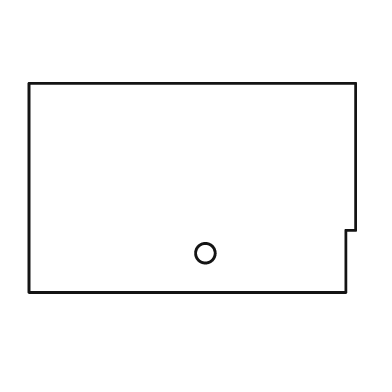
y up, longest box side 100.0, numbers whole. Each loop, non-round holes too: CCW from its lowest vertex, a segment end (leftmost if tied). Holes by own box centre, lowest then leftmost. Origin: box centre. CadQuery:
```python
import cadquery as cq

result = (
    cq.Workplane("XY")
    .moveTo(-50.0, -32.0)
    .lineTo(47.0, -32.0)
    .lineTo(47.0, -13.0)
    .lineTo(50.0, -13.0)
    .lineTo(50.0, 32.0)
    .lineTo(-50.0, 32.0)
    .close()
    .moveTo(4.0, -20.0)
    .circle(3.0)
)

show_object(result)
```